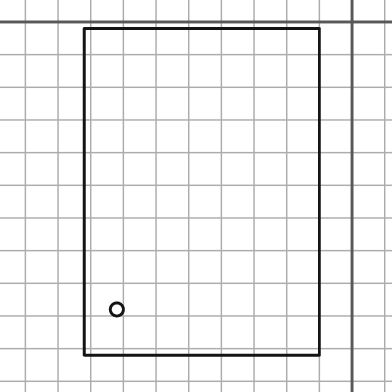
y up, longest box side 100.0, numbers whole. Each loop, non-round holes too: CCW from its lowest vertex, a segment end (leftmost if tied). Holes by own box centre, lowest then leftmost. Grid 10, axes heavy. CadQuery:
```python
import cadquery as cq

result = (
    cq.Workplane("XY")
    .moveTo(-82.0, -102.0)
    .lineTo(-10.0, -102.0)
    .lineTo(-10.0, -2.0)
    .lineTo(-82.0, -2.0)
    .close()
    .moveTo(-72.0, -88.0)
    .circle(2.0)
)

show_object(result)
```